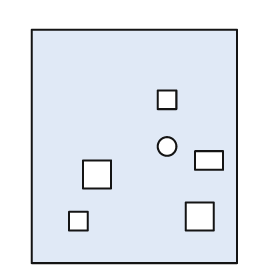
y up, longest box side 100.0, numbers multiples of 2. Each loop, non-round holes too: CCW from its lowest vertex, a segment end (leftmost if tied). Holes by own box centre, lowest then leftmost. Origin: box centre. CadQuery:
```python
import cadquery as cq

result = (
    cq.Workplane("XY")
    .moveTo(-44.0, -50.0)
    .lineTo(44.0, -50.0)
    .lineTo(44.0, 50.0)
    .lineTo(-44.0, 50.0)
    .close()
    .moveTo(-28.0, -36.0)
    .lineTo(-20.0, -36.0)
    .lineTo(-20.0, -28.0)
    .lineTo(-28.0, -28.0)
    .close()
    .moveTo(22.0, -36.0)
    .lineTo(34.0, -36.0)
    .lineTo(34.0, -24.0)
    .lineTo(22.0, -24.0)
    .close()
    .moveTo(-22.0, -18.0)
    .lineTo(-10.0, -18.0)
    .lineTo(-10.0, -6.0)
    .lineTo(-22.0, -6.0)
    .close()
    .moveTo(26.0, -10.0)
    .lineTo(38.0, -10.0)
    .lineTo(38.0, -2.0)
    .lineTo(26.0, -2.0)
    .close()
    .moveTo(14.0, 0.0)
    .circle(4.0)
    .moveTo(10.0, 16.0)
    .lineTo(18.0, 16.0)
    .lineTo(18.0, 24.0)
    .lineTo(10.0, 24.0)
    .close()
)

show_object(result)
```